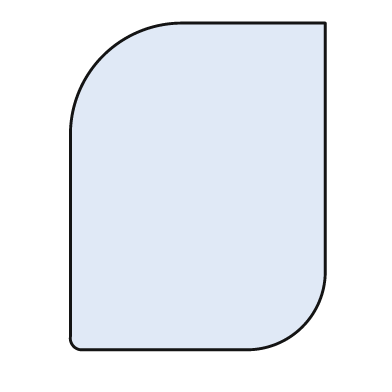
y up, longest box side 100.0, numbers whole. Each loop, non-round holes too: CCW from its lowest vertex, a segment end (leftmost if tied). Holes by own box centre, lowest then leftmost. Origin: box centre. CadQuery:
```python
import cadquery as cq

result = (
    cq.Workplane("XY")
    .moveTo(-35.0, -50.0)
    .lineTo(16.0, -50.0)
    .threePointArc((32.0, -43.0), (39.0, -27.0))
    .lineTo(39.0, 50.0)
    .lineTo(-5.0, 50.0)
    .threePointArc((-29.0, 40.0), (-39.0, 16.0))
    .lineTo(-39.0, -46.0)
    .threePointArc((-38.0, -49.0), (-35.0, -50.0))
    .close()
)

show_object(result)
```